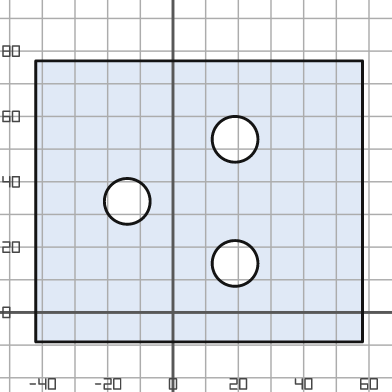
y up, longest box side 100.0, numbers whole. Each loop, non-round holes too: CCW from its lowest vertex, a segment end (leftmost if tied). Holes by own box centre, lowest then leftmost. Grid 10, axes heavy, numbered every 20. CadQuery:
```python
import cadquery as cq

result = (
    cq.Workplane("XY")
    .moveTo(-42.0, -9.0)
    .lineTo(58.0, -9.0)
    .lineTo(58.0, 77.0)
    .lineTo(-42.0, 77.0)
    .close()
    .moveTo(19.0, 15.0)
    .circle(7.0)
    .moveTo(-14.0, 34.0)
    .circle(7.0)
    .moveTo(19.0, 53.0)
    .circle(7.0)
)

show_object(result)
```